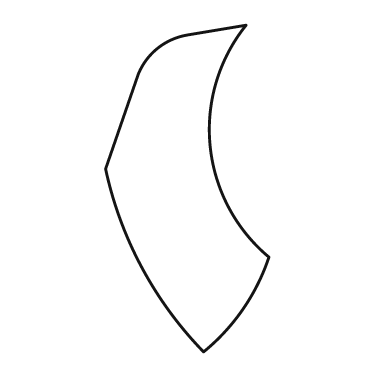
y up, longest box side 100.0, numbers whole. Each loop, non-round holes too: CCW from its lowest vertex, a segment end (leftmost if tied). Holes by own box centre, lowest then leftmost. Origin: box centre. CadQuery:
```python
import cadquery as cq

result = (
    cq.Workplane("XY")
    .moveTo(5.0, -50.0)
    .threePointArc((17.0, -37.0), (25.0, -21.0))
    .threePointArc((7.0, 13.0), (18.0, 50.0))
    .lineTo(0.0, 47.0)
    .threePointArc((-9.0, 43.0), (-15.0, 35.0))
    .lineTo(-25.0, 6.0)
    .threePointArc((-14.0, -24.0), (5.0, -50.0))
    .close()
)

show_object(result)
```